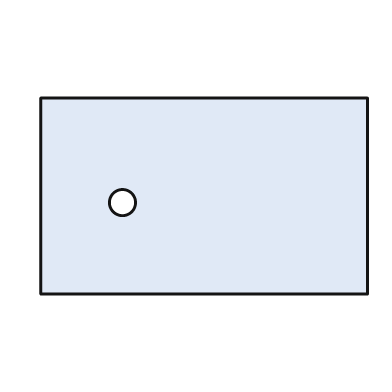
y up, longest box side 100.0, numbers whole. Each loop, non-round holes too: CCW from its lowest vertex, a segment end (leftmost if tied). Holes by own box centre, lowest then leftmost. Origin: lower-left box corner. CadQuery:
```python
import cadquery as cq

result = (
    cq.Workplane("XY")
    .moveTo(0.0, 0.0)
    .lineTo(100.0, 0.0)
    .lineTo(100.0, 60.0)
    .lineTo(0.0, 60.0)
    .close()
    .moveTo(25.0, 28.0)
    .circle(4.0)
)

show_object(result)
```